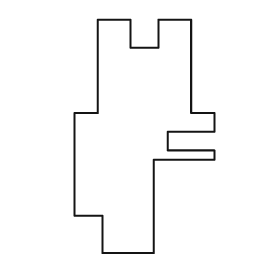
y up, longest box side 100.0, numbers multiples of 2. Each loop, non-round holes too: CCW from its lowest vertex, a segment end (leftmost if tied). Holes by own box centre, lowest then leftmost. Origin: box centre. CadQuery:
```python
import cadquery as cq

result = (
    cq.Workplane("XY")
    .moveTo(-18.0, -50.0)
    .lineTo(4.0, -50.0)
    .lineTo(4.0, -10.0)
    .lineTo(30.0, -10.0)
    .lineTo(30.0, -6.0)
    .lineTo(10.0, -6.0)
    .lineTo(10.0, 2.0)
    .lineTo(30.0, 2.0)
    .lineTo(30.0, 10.0)
    .lineTo(20.0, 10.0)
    .lineTo(20.0, 50.0)
    .lineTo(6.0, 50.0)
    .lineTo(6.0, 38.0)
    .lineTo(-6.0, 38.0)
    .lineTo(-6.0, 50.0)
    .lineTo(-20.0, 50.0)
    .lineTo(-20.0, 10.0)
    .lineTo(-30.0, 10.0)
    .lineTo(-30.0, -34.0)
    .lineTo(-18.0, -34.0)
    .close()
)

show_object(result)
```